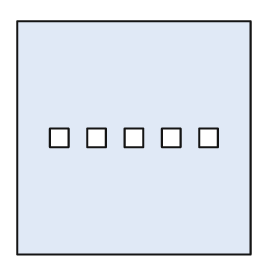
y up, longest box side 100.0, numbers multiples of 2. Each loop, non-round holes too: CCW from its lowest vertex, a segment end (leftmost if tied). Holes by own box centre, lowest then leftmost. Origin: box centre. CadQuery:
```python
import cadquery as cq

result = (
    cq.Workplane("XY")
    .moveTo(-50.0, -50.0)
    .lineTo(50.0, -50.0)
    .lineTo(50.0, 50.0)
    .lineTo(-50.0, 50.0)
    .close()
    .moveTo(-36.0, -4.0)
    .lineTo(-28.0, -4.0)
    .lineTo(-28.0, 4.0)
    .lineTo(-36.0, 4.0)
    .close()
    .moveTo(-20.0, -4.0)
    .lineTo(-12.0, -4.0)
    .lineTo(-12.0, 4.0)
    .lineTo(-20.0, 4.0)
    .close()
    .moveTo(-4.0, -4.0)
    .lineTo(4.0, -4.0)
    .lineTo(4.0, 4.0)
    .lineTo(-4.0, 4.0)
    .close()
    .moveTo(12.0, -4.0)
    .lineTo(20.0, -4.0)
    .lineTo(20.0, 4.0)
    .lineTo(12.0, 4.0)
    .close()
    .moveTo(28.0, -4.0)
    .lineTo(36.0, -4.0)
    .lineTo(36.0, 4.0)
    .lineTo(28.0, 4.0)
    .close()
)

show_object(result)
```